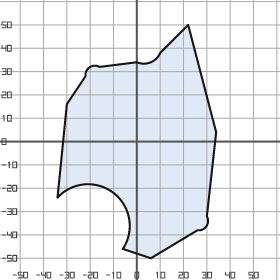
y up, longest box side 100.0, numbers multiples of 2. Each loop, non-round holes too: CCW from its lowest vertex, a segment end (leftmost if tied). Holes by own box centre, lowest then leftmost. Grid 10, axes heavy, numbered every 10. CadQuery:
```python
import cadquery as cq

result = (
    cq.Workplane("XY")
    .moveTo(6.0, -50.0)
    .lineTo(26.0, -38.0)
    .threePointArc((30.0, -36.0), (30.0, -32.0))
    .lineTo(34.0, 4.0)
    .lineTo(22.0, 50.0)
    .lineTo(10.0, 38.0)
    .threePointArc((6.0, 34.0), (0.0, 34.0))
    .lineTo(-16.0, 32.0)
    .threePointArc((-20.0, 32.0), (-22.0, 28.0))
    .lineTo(-30.0, 16.0)
    .lineTo(-34.0, -24.0)
    .threePointArc((-10.0, -22.0), (-6.0, -46.0))
    .close()
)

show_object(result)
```